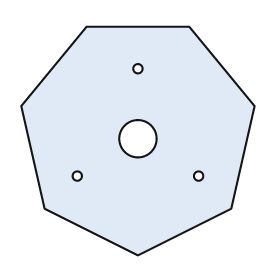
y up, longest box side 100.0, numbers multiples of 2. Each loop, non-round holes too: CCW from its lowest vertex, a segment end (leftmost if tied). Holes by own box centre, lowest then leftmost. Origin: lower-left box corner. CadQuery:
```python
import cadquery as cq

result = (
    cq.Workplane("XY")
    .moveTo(50.0, 0.0)
    .lineTo(90.0, 20.0)
    .lineTo(100.0, 64.0)
    .lineTo(72.0, 98.0)
    .lineTo(28.0, 98.0)
    .lineTo(0.0, 64.0)
    .lineTo(10.0, 20.0)
    .close()
    .moveTo(24.0, 34.0)
    .circle(2.0)
    .moveTo(76.0, 34.0)
    .circle(2.0)
    .moveTo(50.0, 50.0)
    .circle(8.0)
    .moveTo(50.0, 80.0)
    .circle(2.0)
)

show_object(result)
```